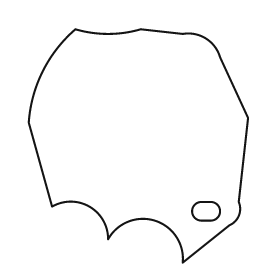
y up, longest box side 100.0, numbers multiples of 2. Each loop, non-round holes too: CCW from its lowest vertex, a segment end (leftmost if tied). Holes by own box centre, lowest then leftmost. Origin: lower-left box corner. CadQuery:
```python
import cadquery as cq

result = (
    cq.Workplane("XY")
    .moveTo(66.0, 0.0)
    .lineTo(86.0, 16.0)
    .threePointArc((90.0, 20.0), (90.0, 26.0))
    .lineTo(94.0, 62.0)
    .lineTo(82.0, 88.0)
    .threePointArc((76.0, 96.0), (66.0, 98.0))
    .lineTo(48.0, 100.0)
    .threePointArc((34.0, 98.0), (20.0, 100.0))
    .threePointArc((6.0, 82.0), (0.0, 60.0))
    .lineTo(10.0, 24.0)
    .threePointArc((26.0, 24.0), (34.0, 10.0))
    .threePointArc((54.0, 18.0), (66.0, 0.0))
    .close()
    .moveTo(74.0, 18.0)
    .lineTo(78.0, 18.0)
    .threePointArc((82.0, 22.0), (78.0, 26.0))
    .lineTo(74.0, 26.0)
    .threePointArc((70.0, 22.0), (74.0, 18.0))
    .close()
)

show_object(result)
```